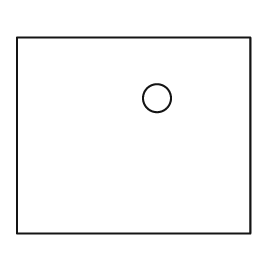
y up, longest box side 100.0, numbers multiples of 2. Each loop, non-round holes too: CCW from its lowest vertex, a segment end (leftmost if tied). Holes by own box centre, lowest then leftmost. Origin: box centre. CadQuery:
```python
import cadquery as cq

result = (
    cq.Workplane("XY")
    .moveTo(-50.0, -42.0)
    .lineTo(50.0, -42.0)
    .lineTo(50.0, 42.0)
    .lineTo(-50.0, 42.0)
    .close()
    .moveTo(10.0, 16.0)
    .circle(6.0)
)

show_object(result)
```